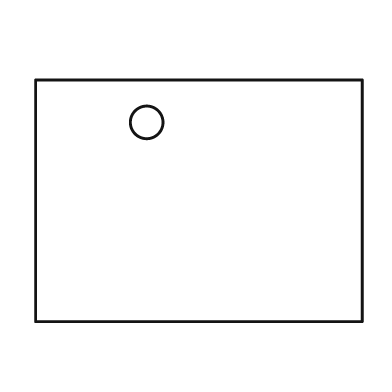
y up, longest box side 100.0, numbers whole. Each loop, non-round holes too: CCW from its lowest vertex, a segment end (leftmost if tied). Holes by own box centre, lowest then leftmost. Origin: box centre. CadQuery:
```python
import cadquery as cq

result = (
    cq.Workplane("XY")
    .moveTo(-50.0, -37.0)
    .lineTo(50.0, -37.0)
    .lineTo(50.0, 37.0)
    .lineTo(-50.0, 37.0)
    .close()
    .moveTo(-16.0, 24.0)
    .circle(5.0)
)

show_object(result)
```